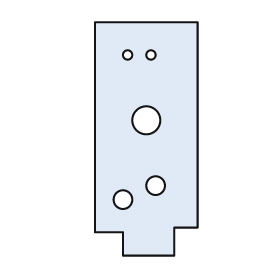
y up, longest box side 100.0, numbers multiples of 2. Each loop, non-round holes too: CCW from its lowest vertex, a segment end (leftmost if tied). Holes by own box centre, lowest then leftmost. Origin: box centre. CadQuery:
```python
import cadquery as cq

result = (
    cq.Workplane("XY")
    .moveTo(-10.0, -50.0)
    .lineTo(12.0, -50.0)
    .lineTo(12.0, -38.0)
    .lineTo(22.0, -38.0)
    .lineTo(22.0, 50.0)
    .lineTo(-22.0, 50.0)
    .lineTo(-22.0, -40.0)
    .lineTo(-10.0, -40.0)
    .close()
    .moveTo(-10.0, -26.0)
    .circle(4.0)
    .moveTo(4.0, -20.0)
    .circle(4.0)
    .moveTo(0.0, 8.0)
    .circle(6.0)
    .moveTo(-8.0, 36.0)
    .circle(2.0)
    .moveTo(2.0, 36.0)
    .circle(2.0)
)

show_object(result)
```